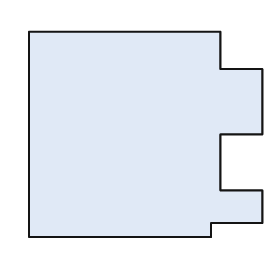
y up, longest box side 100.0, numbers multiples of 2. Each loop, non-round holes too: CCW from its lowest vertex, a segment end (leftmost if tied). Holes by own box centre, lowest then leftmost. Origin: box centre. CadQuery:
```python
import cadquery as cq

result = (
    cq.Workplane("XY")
    .moveTo(-50.0, -44.0)
    .lineTo(28.0, -44.0)
    .lineTo(28.0, -38.0)
    .lineTo(50.0, -38.0)
    .lineTo(50.0, -24.0)
    .lineTo(32.0, -24.0)
    .lineTo(32.0, 0.0)
    .lineTo(50.0, 0.0)
    .lineTo(50.0, 28.0)
    .lineTo(32.0, 28.0)
    .lineTo(32.0, 44.0)
    .lineTo(-50.0, 44.0)
    .close()
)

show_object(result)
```